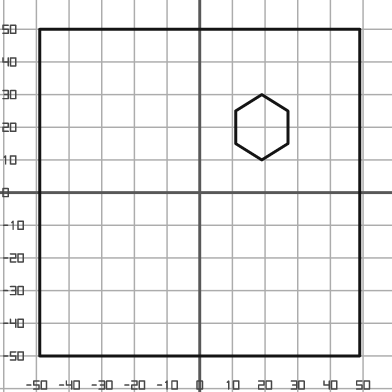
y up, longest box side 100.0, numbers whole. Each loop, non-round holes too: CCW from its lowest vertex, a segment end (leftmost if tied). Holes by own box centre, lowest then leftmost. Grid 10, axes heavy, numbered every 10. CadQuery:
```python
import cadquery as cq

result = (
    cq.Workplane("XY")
    .moveTo(-49.0, -50.0)
    .lineTo(49.0, -50.0)
    .lineTo(49.0, 50.0)
    .lineTo(-49.0, 50.0)
    .close()
    .moveTo(19.0, 10.0)
    .lineTo(27.0, 15.0)
    .lineTo(27.0, 25.0)
    .lineTo(19.0, 30.0)
    .lineTo(11.0, 25.0)
    .lineTo(11.0, 15.0)
    .close()
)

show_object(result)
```